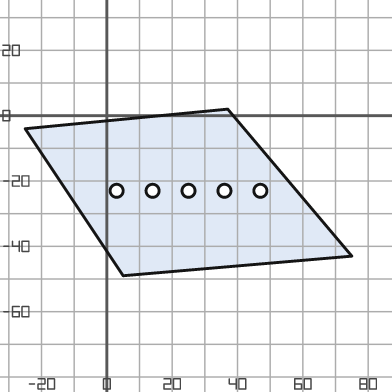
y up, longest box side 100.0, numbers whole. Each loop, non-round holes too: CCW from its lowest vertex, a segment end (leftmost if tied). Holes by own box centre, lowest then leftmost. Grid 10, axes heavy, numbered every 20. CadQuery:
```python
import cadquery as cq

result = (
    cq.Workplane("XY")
    .moveTo(5.0, -49.0)
    .lineTo(75.0, -43.0)
    .lineTo(37.0, 2.0)
    .lineTo(-25.0, -4.0)
    .close()
    .moveTo(3.0, -23.0)
    .circle(2.0)
    .moveTo(14.0, -23.0)
    .circle(2.0)
    .moveTo(25.0, -23.0)
    .circle(2.0)
    .moveTo(36.0, -23.0)
    .circle(2.0)
    .moveTo(47.0, -23.0)
    .circle(2.0)
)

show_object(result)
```